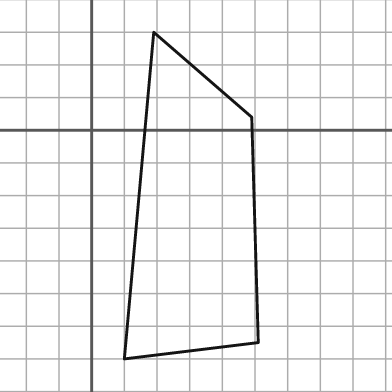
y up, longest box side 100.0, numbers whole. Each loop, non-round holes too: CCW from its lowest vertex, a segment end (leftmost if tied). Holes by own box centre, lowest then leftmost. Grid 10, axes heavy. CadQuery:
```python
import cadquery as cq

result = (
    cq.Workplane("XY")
    .moveTo(10.0, -70.0)
    .lineTo(51.0, -65.0)
    .lineTo(49.0, 4.0)
    .lineTo(19.0, 30.0)
    .close()
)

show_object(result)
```